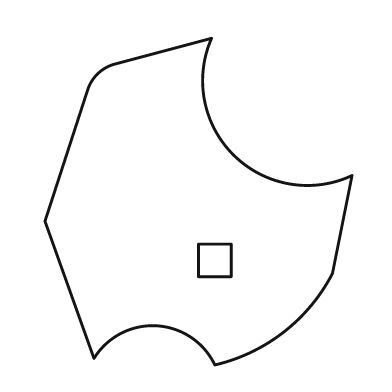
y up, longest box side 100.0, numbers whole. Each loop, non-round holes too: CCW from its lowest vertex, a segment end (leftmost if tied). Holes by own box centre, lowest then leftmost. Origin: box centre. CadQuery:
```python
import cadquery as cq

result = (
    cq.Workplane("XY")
    .moveTo(5.0, -50.0)
    .threePointArc((26.0, -40.0), (41.0, -22.0))
    .lineTo(47.0, 8.0)
    .threePointArc((11.0, 14.0), (4.0, 50.0))
    .lineTo(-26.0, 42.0)
    .threePointArc((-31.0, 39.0), (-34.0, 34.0))
    .lineTo(-47.0, -6.0)
    .lineTo(-32.0, -48.0)
    .threePointArc((-13.0, -38.0), (5.0, -50.0))
    .close()
    .moveTo(0.0, -23.0)
    .lineTo(10.0, -23.0)
    .lineTo(10.0, -13.0)
    .lineTo(0.0, -13.0)
    .close()
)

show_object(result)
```